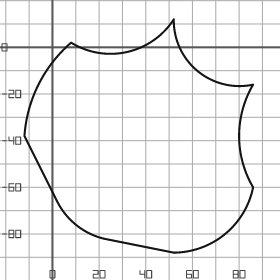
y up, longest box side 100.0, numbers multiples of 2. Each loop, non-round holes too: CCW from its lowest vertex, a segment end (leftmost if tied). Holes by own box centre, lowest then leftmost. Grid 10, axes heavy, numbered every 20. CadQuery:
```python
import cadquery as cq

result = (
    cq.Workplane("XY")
    .moveTo(52.0, -88.0)
    .threePointArc((74.0, -80.0), (86.0, -60.0))
    .threePointArc((80.0, -38.0), (86.0, -16.0))
    .threePointArc((62.0, -10.0), (52.0, 12.0))
    .threePointArc((32.0, -2.0), (8.0, 2.0))
    .threePointArc((-6.0, -16.0), (-12.0, -38.0))
    .lineTo(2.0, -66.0)
    .threePointArc((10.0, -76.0), (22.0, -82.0))
    .close()
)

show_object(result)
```